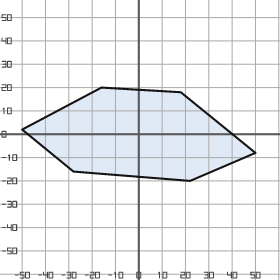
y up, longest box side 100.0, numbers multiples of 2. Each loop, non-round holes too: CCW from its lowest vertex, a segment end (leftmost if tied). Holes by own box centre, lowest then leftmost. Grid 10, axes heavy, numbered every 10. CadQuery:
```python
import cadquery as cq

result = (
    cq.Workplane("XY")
    .moveTo(22.0, -20.0)
    .lineTo(50.0, -8.0)
    .lineTo(18.0, 18.0)
    .lineTo(-16.0, 20.0)
    .lineTo(-50.0, 2.0)
    .lineTo(-28.0, -16.0)
    .close()
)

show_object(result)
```